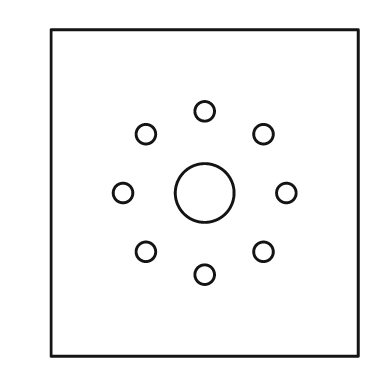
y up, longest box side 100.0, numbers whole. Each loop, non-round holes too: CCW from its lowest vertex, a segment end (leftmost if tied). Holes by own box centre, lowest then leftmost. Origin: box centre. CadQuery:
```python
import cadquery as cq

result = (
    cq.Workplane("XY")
    .moveTo(-47.0, -50.0)
    .lineTo(47.0, -50.0)
    .lineTo(47.0, 50.0)
    .lineTo(-47.0, 50.0)
    .close()
    .moveTo(0.0, -25.0)
    .circle(3.0)
    .moveTo(-18.0, -18.0)
    .circle(3.0)
    .moveTo(18.0, -18.0)
    .circle(3.0)
    .moveTo(-25.0, 0.0)
    .circle(3.0)
    .moveTo(0.0, 0.0)
    .circle(9.0)
    .moveTo(25.0, 0.0)
    .circle(3.0)
    .moveTo(-18.0, 18.0)
    .circle(3.0)
    .moveTo(18.0, 18.0)
    .circle(3.0)
    .moveTo(0.0, 25.0)
    .circle(3.0)
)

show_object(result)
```